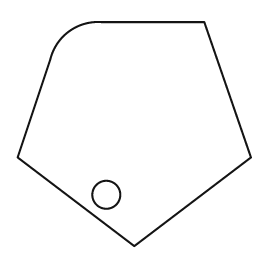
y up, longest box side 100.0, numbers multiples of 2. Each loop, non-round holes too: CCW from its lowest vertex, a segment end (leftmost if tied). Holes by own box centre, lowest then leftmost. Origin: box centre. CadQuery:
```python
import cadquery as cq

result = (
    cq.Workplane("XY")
    .moveTo(0.0, -48.0)
    .lineTo(50.0, -10.0)
    .lineTo(30.0, 48.0)
    .lineTo(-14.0, 48.0)
    .threePointArc((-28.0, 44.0), (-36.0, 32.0))
    .lineTo(-50.0, -10.0)
    .close()
    .moveTo(-12.0, -26.0)
    .circle(6.0)
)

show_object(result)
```